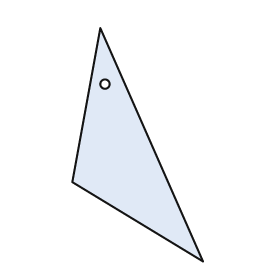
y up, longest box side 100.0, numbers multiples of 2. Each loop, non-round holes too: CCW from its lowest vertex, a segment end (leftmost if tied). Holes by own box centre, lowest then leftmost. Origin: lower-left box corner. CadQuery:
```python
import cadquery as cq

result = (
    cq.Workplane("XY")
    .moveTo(56.0, 0.0)
    .lineTo(12.0, 100.0)
    .lineTo(0.0, 34.0)
    .close()
    .moveTo(14.0, 76.0)
    .circle(2.0)
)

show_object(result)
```